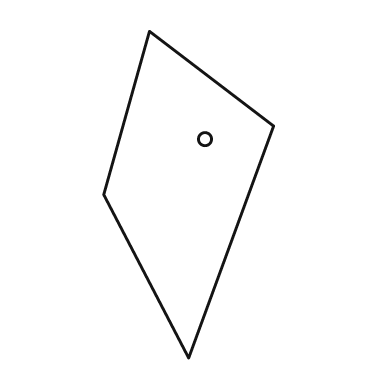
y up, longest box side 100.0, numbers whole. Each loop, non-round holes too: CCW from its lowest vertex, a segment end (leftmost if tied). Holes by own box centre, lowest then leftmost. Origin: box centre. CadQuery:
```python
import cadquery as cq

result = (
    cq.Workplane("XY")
    .moveTo(0.0, -50.0)
    .lineTo(26.0, 21.0)
    .lineTo(-12.0, 50.0)
    .lineTo(-26.0, 0.0)
    .close()
    .moveTo(5.0, 17.0)
    .circle(2.0)
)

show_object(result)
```